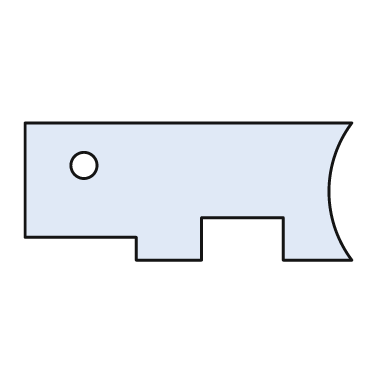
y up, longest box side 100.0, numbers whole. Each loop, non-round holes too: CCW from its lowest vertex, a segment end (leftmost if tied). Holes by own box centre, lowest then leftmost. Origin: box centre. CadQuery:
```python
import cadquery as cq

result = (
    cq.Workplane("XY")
    .moveTo(-16.0, -21.0)
    .lineTo(4.0, -21.0)
    .lineTo(4.0, -8.0)
    .lineTo(29.0, -8.0)
    .lineTo(29.0, -21.0)
    .lineTo(50.0, -21.0)
    .threePointArc((43.0, 0.0), (50.0, 21.0))
    .lineTo(-50.0, 21.0)
    .lineTo(-50.0, -14.0)
    .lineTo(-16.0, -14.0)
    .close()
    .moveTo(-32.0, 8.0)
    .circle(4.0)
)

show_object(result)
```